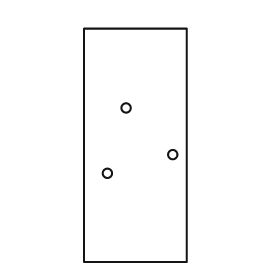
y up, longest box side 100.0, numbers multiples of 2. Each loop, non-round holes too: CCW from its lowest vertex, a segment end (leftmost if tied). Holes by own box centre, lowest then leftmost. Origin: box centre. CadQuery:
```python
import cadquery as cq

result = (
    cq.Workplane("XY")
    .moveTo(-22.0, -50.0)
    .lineTo(22.0, -50.0)
    .lineTo(22.0, 50.0)
    .lineTo(-22.0, 50.0)
    .close()
    .moveTo(-12.0, -12.0)
    .circle(2.0)
    .moveTo(16.0, -4.0)
    .circle(2.0)
    .moveTo(-4.0, 16.0)
    .circle(2.0)
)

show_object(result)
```